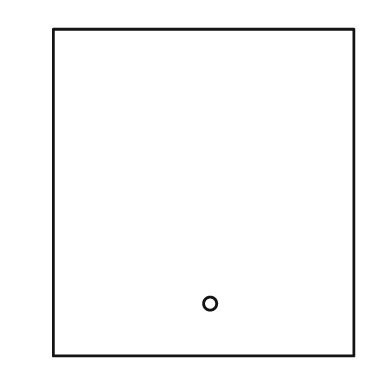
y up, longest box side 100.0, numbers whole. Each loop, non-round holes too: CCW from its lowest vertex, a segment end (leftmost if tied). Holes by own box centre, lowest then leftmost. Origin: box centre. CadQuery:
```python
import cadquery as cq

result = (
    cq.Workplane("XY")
    .moveTo(-46.0, -50.0)
    .lineTo(46.0, -50.0)
    .lineTo(46.0, 50.0)
    .lineTo(-46.0, 50.0)
    .close()
    .moveTo(2.0, -34.0)
    .circle(2.0)
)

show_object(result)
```